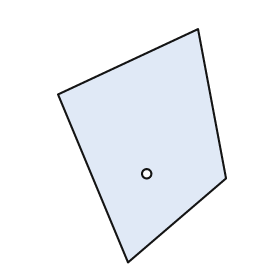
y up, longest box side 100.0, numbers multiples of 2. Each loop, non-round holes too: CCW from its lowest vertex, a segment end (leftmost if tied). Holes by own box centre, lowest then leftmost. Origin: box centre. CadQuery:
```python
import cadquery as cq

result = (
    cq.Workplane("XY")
    .moveTo(-6.0, -50.0)
    .lineTo(36.0, -14.0)
    .lineTo(24.0, 50.0)
    .lineTo(-36.0, 22.0)
    .close()
    .moveTo(2.0, -12.0)
    .circle(2.0)
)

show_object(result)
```